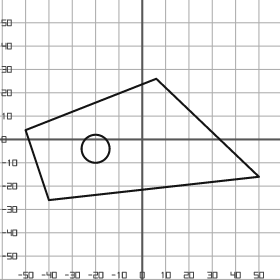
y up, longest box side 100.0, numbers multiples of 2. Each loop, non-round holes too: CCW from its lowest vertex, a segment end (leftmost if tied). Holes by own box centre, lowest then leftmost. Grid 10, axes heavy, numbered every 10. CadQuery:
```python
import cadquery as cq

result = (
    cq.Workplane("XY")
    .moveTo(-40.0, -26.0)
    .lineTo(50.0, -16.0)
    .lineTo(6.0, 26.0)
    .lineTo(-50.0, 4.0)
    .close()
    .moveTo(-20.0, -4.0)
    .circle(6.0)
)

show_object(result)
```